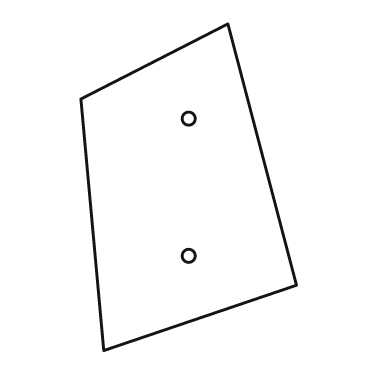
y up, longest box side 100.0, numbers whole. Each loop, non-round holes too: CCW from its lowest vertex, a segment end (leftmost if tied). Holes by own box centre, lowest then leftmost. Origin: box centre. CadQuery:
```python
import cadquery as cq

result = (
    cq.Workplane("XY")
    .moveTo(-26.0, -50.0)
    .lineTo(33.0, -30.0)
    .lineTo(12.0, 50.0)
    .lineTo(-33.0, 27.0)
    .close()
    .moveTo(0.0, -21.0)
    .circle(2.0)
    .moveTo(0.0, 21.0)
    .circle(2.0)
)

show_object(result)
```